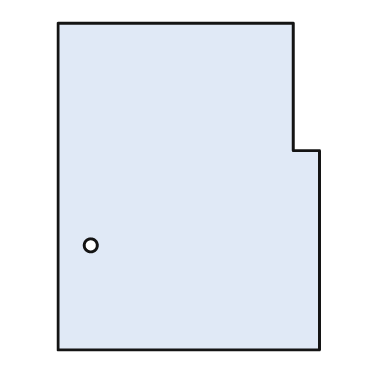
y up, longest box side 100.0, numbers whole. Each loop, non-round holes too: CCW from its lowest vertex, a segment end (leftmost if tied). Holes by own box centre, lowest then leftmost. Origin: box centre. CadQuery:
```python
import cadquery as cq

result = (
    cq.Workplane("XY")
    .moveTo(-40.0, -50.0)
    .lineTo(40.0, -50.0)
    .lineTo(40.0, 11.0)
    .lineTo(32.0, 11.0)
    .lineTo(32.0, 50.0)
    .lineTo(-40.0, 50.0)
    .close()
    .moveTo(-30.0, -18.0)
    .circle(2.0)
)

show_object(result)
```